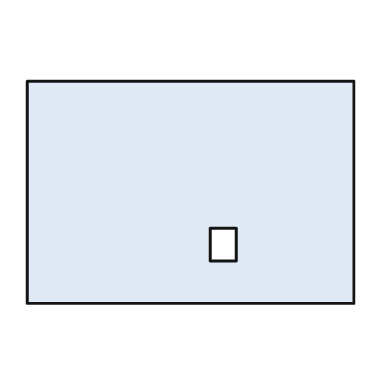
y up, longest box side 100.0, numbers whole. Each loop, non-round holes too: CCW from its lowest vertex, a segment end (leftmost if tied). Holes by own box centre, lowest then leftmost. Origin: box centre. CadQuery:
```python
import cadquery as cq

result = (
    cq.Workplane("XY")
    .moveTo(-50.0, -34.0)
    .lineTo(50.0, -34.0)
    .lineTo(50.0, 34.0)
    .lineTo(-50.0, 34.0)
    .close()
    .moveTo(6.0, -21.0)
    .lineTo(14.0, -21.0)
    .lineTo(14.0, -11.0)
    .lineTo(6.0, -11.0)
    .close()
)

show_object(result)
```